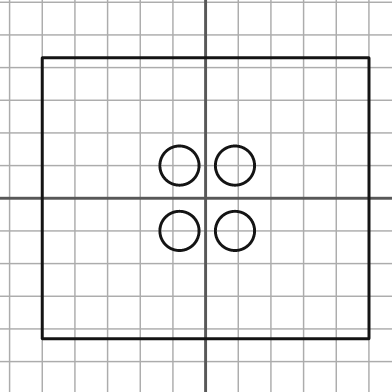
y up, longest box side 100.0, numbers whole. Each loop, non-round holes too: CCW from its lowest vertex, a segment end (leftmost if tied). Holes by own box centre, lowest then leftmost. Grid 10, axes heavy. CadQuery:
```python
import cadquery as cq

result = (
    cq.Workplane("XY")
    .moveTo(-50.0, -43.0)
    .lineTo(50.0, -43.0)
    .lineTo(50.0, 43.0)
    .lineTo(-50.0, 43.0)
    .close()
    .moveTo(-8.0, -10.0)
    .circle(6.0)
    .moveTo(9.0, -10.0)
    .circle(6.0)
    .moveTo(-8.0, 10.0)
    .circle(6.0)
    .moveTo(9.0, 10.0)
    .circle(6.0)
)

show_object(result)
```